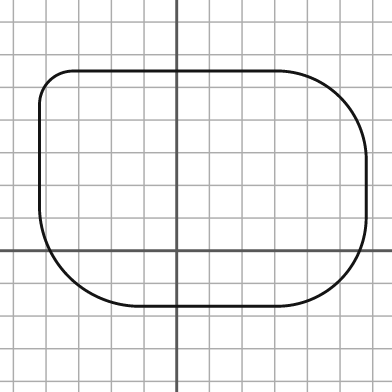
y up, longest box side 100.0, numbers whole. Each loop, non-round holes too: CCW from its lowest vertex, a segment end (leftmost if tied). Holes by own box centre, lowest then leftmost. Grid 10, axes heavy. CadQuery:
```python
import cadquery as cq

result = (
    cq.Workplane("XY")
    .moveTo(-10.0, -17.0)
    .lineTo(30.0, -17.0)
    .threePointArc((50.0, -9.0), (58.0, 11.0))
    .lineTo(58.0, 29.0)
    .threePointArc((50.0, 47.0), (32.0, 55.0))
    .lineTo(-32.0, 55.0)
    .threePointArc((-39.0, 52.0), (-42.0, 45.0))
    .lineTo(-42.0, 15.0)
    .threePointArc((-33.0, -8.0), (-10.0, -17.0))
    .close()
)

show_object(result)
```